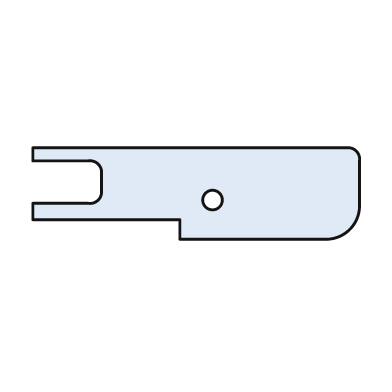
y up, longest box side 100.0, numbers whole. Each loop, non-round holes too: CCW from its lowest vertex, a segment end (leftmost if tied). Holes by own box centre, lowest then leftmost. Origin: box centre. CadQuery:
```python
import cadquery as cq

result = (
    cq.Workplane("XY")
    .moveTo(-5.0, -14.0)
    .lineTo(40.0, -14.0)
    .threePointArc((47.0, -11.0), (50.0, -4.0))
    .lineTo(50.0, 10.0)
    .threePointArc((49.0, 13.0), (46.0, 14.0))
    .lineTo(-50.0, 14.0)
    .lineTo(-50.0, 10.0)
    .lineTo(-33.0, 10.0)
    .threePointArc((-30.0, 9.0), (-29.0, 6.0))
    .lineTo(-29.0, 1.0)
    .threePointArc((-30.0, -2.0), (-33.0, -3.0))
    .lineTo(-50.0, -3.0)
    .lineTo(-50.0, -8.0)
    .lineTo(-5.0, -8.0)
    .close()
    .moveTo(5.0, -2.0)
    .circle(3.0)
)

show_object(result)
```